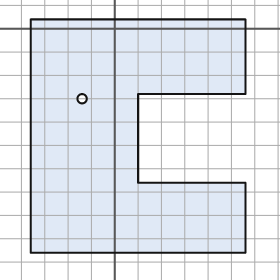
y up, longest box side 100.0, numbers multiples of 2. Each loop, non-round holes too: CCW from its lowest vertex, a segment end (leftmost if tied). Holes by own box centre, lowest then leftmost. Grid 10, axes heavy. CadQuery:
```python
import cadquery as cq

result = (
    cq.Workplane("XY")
    .moveTo(-36.0, -96.0)
    .lineTo(56.0, -96.0)
    .lineTo(56.0, -66.0)
    .lineTo(10.0, -66.0)
    .lineTo(10.0, -28.0)
    .lineTo(56.0, -28.0)
    .lineTo(56.0, 4.0)
    .lineTo(-36.0, 4.0)
    .close()
    .moveTo(-14.0, -30.0)
    .circle(2.0)
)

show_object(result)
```